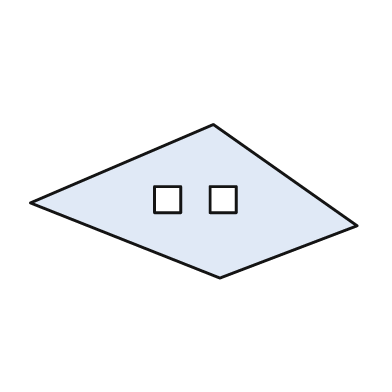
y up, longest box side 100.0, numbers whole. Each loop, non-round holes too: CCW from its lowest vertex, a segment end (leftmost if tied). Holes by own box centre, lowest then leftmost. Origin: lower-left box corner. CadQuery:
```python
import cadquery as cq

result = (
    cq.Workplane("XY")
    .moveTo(58.0, 0.0)
    .lineTo(100.0, 16.0)
    .lineTo(56.0, 47.0)
    .lineTo(0.0, 23.0)
    .close()
    .moveTo(38.0, 20.0)
    .lineTo(46.0, 20.0)
    .lineTo(46.0, 28.0)
    .lineTo(38.0, 28.0)
    .close()
    .moveTo(55.0, 20.0)
    .lineTo(63.0, 20.0)
    .lineTo(63.0, 28.0)
    .lineTo(55.0, 28.0)
    .close()
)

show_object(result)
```